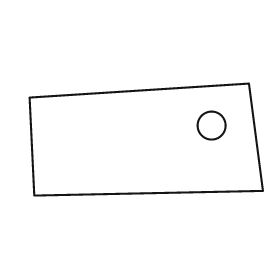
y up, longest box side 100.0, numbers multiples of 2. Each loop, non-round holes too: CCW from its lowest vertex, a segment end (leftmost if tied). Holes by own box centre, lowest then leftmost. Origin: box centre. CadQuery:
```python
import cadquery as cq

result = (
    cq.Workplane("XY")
    .moveTo(-48.0, -24.0)
    .lineTo(50.0, -22.0)
    .lineTo(44.0, 24.0)
    .lineTo(-50.0, 18.0)
    .close()
    .moveTo(28.0, 6.0)
    .circle(6.0)
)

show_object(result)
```